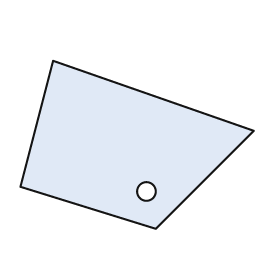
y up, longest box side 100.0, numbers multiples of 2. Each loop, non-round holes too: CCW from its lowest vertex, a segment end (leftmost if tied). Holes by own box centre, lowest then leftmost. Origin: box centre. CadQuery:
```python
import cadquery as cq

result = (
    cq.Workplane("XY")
    .moveTo(8.0, -36.0)
    .lineTo(50.0, 6.0)
    .lineTo(-36.0, 36.0)
    .lineTo(-50.0, -18.0)
    .close()
    .moveTo(4.0, -20.0)
    .circle(4.0)
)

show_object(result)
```